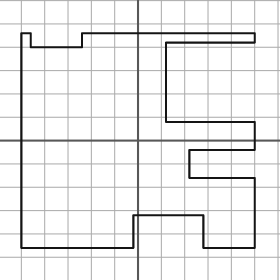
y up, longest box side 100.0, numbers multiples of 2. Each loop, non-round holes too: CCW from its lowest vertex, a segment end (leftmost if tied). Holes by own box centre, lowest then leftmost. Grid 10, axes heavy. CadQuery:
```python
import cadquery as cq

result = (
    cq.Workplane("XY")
    .moveTo(-50.0, -46.0)
    .lineTo(-2.0, -46.0)
    .lineTo(-2.0, -32.0)
    .lineTo(28.0, -32.0)
    .lineTo(28.0, -46.0)
    .lineTo(50.0, -46.0)
    .lineTo(50.0, -16.0)
    .lineTo(22.0, -16.0)
    .lineTo(22.0, -4.0)
    .lineTo(50.0, -4.0)
    .lineTo(50.0, 8.0)
    .lineTo(12.0, 8.0)
    .lineTo(12.0, 42.0)
    .lineTo(50.0, 42.0)
    .lineTo(50.0, 46.0)
    .lineTo(-24.0, 46.0)
    .lineTo(-24.0, 40.0)
    .lineTo(-46.0, 40.0)
    .lineTo(-46.0, 46.0)
    .lineTo(-50.0, 46.0)
    .close()
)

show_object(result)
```